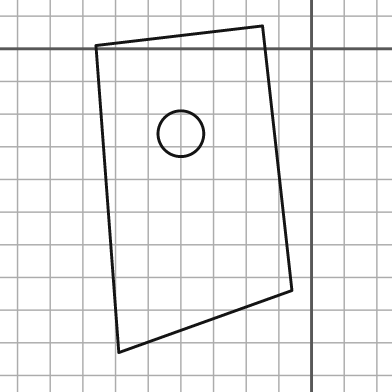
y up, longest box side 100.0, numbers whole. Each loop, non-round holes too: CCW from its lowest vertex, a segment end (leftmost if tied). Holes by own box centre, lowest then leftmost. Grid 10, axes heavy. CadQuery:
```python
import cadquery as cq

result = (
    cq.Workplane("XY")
    .moveTo(-59.0, -93.0)
    .lineTo(-6.0, -74.0)
    .lineTo(-15.0, 7.0)
    .lineTo(-66.0, 1.0)
    .close()
    .moveTo(-40.0, -26.0)
    .circle(7.0)
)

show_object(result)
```